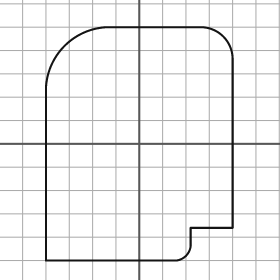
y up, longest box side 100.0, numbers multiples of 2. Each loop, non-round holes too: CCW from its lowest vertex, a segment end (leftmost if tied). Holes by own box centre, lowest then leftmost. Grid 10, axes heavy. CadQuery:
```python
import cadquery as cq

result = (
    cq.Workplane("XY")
    .moveTo(-40.0, -50.0)
    .lineTo(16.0, -50.0)
    .threePointArc((20.0, -48.0), (22.0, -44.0))
    .lineTo(22.0, -36.0)
    .lineTo(40.0, -36.0)
    .lineTo(40.0, 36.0)
    .threePointArc((36.0, 46.0), (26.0, 50.0))
    .lineTo(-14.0, 50.0)
    .threePointArc((-32.0, 42.0), (-40.0, 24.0))
    .close()
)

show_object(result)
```